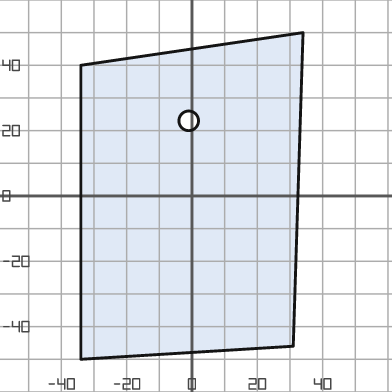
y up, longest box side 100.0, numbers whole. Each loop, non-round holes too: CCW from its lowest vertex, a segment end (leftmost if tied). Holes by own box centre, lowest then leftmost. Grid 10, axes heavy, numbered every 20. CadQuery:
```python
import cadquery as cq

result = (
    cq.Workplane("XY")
    .moveTo(-34.0, -50.0)
    .lineTo(31.0, -46.0)
    .lineTo(34.0, 50.0)
    .lineTo(-34.0, 40.0)
    .close()
    .moveTo(-1.0, 23.0)
    .circle(3.0)
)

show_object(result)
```